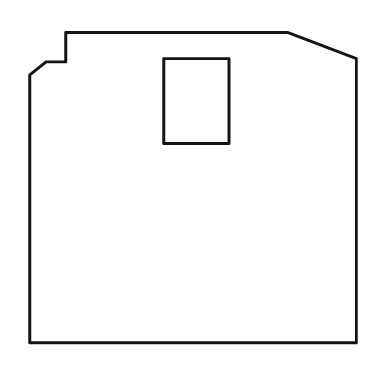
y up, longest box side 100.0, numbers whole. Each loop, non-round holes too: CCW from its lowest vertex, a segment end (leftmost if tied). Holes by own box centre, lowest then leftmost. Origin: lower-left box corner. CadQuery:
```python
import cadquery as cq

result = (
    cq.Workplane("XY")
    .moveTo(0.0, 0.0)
    .lineTo(100.0, 0.0)
    .lineTo(100.0, 87.0)
    .lineTo(79.0, 95.0)
    .lineTo(11.0, 95.0)
    .lineTo(11.0, 86.0)
    .lineTo(5.0, 86.0)
    .lineTo(0.0, 82.0)
    .close()
    .moveTo(41.0, 61.0)
    .lineTo(61.0, 61.0)
    .lineTo(61.0, 87.0)
    .lineTo(41.0, 87.0)
    .close()
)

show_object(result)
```